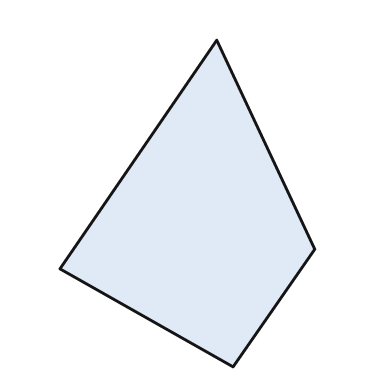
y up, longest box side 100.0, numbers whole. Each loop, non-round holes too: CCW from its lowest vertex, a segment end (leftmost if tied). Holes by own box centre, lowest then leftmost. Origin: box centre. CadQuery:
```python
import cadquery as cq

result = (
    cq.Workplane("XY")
    .moveTo(14.0, -50.0)
    .lineTo(39.0, -14.0)
    .lineTo(9.0, 50.0)
    .lineTo(-39.0, -20.0)
    .close()
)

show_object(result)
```